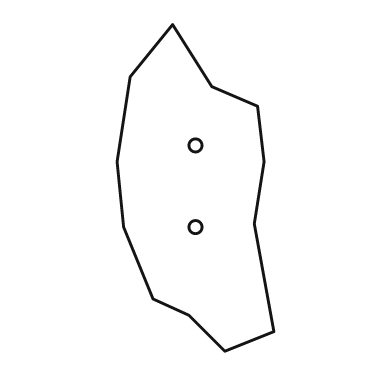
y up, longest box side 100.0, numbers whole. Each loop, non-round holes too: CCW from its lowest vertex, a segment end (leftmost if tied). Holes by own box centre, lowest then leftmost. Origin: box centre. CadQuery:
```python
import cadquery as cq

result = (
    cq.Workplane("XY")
    .moveTo(9.0, -50.0)
    .lineTo(24.0, -44.0)
    .lineTo(18.0, -11.0)
    .lineTo(21.0, 8.0)
    .lineTo(19.0, 25.0)
    .lineTo(5.0, 31.0)
    .lineTo(-7.0, 50.0)
    .lineTo(-20.0, 34.0)
    .lineTo(-24.0, 8.0)
    .lineTo(-22.0, -12.0)
    .lineTo(-13.0, -34.0)
    .lineTo(-2.0, -39.0)
    .close()
    .moveTo(0.0, -12.0)
    .circle(2.0)
    .moveTo(0.0, 13.0)
    .circle(2.0)
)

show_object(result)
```